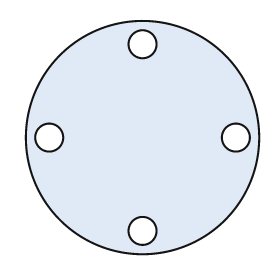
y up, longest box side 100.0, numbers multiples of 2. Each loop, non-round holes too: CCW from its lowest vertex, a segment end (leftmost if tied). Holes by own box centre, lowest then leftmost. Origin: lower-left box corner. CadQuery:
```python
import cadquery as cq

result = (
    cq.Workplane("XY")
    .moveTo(50.0, 50.0)
    .circle(50.0)
    .moveTo(50.0, 10.0)
    .circle(6.0)
    .moveTo(10.0, 50.0)
    .circle(6.0)
    .moveTo(90.0, 50.0)
    .circle(6.0)
    .moveTo(50.0, 90.0)
    .circle(6.0)
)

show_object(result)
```